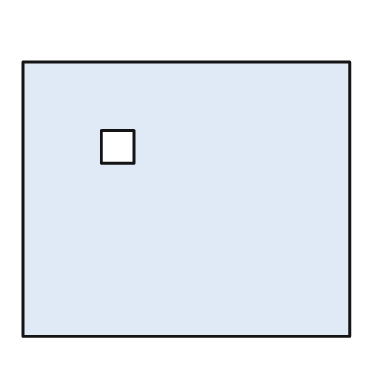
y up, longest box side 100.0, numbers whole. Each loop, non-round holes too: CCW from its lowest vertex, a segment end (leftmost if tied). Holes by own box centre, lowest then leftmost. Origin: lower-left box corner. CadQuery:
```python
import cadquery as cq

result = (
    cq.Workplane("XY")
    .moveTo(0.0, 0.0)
    .lineTo(100.0, 0.0)
    .lineTo(100.0, 84.0)
    .lineTo(0.0, 84.0)
    .close()
    .moveTo(24.0, 53.0)
    .lineTo(34.0, 53.0)
    .lineTo(34.0, 63.0)
    .lineTo(24.0, 63.0)
    .close()
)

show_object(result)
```